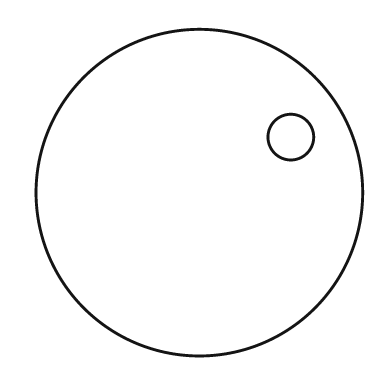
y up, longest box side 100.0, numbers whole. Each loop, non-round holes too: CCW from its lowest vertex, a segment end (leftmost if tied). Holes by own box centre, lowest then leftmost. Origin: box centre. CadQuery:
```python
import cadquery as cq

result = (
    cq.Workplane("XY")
    .moveTo(0.0, 0.0)
    .circle(50.0)
    .moveTo(28.0, 17.0)
    .circle(7.0)
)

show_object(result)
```